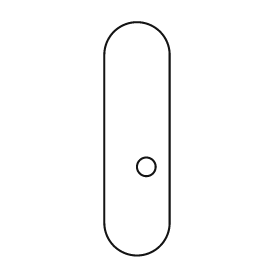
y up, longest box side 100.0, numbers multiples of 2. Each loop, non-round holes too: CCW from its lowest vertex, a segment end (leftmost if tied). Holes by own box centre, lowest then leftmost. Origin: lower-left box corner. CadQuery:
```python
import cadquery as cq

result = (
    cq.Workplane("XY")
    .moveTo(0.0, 14.0)
    .threePointArc((14.0, 0.0), (28.0, 14.0))
    .lineTo(28.0, 86.0)
    .threePointArc((14.0, 100.0), (0.0, 86.0))
    .close()
    .moveTo(18.0, 38.0)
    .circle(4.0)
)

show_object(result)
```